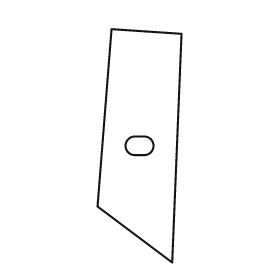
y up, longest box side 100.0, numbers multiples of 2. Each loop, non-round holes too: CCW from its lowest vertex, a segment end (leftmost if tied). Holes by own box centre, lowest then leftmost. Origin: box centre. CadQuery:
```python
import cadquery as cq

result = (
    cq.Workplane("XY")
    .moveTo(14.0, -50.0)
    .lineTo(18.0, 48.0)
    .lineTo(-12.0, 50.0)
    .lineTo(-18.0, -26.0)
    .close()
    .moveTo(-2.0, -4.0)
    .lineTo(2.0, -4.0)
    .threePointArc((6.0, 0.0), (2.0, 4.0))
    .lineTo(-2.0, 4.0)
    .threePointArc((-6.0, 0.0), (-2.0, -4.0))
    .close()
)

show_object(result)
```